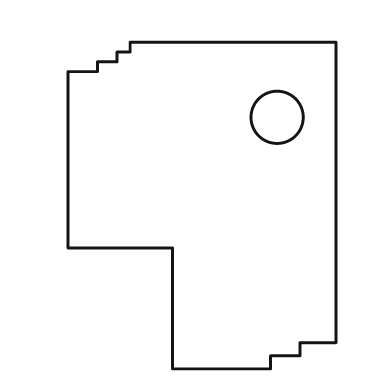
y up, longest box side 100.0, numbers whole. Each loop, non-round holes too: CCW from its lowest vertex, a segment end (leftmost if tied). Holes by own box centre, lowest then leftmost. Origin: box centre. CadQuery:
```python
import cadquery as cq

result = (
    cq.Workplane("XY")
    .moveTo(-9.0, -50.0)
    .lineTo(21.0, -50.0)
    .lineTo(21.0, -46.0)
    .lineTo(30.0, -46.0)
    .lineTo(30.0, -42.0)
    .lineTo(41.0, -42.0)
    .lineTo(41.0, 50.0)
    .lineTo(-22.0, 50.0)
    .lineTo(-22.0, 47.0)
    .lineTo(-26.0, 47.0)
    .lineTo(-26.0, 44.0)
    .lineTo(-32.0, 44.0)
    .lineTo(-32.0, 41.0)
    .lineTo(-41.0, 41.0)
    .lineTo(-41.0, -13.0)
    .lineTo(-9.0, -13.0)
    .close()
    .moveTo(23.0, 27.0)
    .circle(8.0)
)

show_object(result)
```